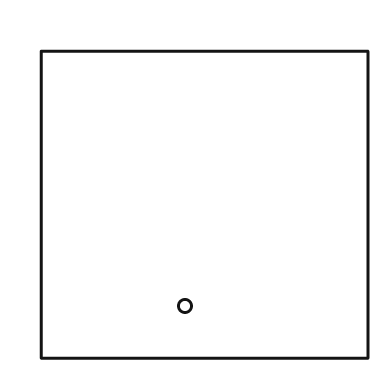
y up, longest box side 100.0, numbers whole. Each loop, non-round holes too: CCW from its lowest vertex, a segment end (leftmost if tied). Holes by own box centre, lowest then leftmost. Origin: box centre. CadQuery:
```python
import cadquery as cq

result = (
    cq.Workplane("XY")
    .moveTo(-50.0, -47.0)
    .lineTo(50.0, -47.0)
    .lineTo(50.0, 47.0)
    .lineTo(-50.0, 47.0)
    .close()
    .moveTo(-6.0, -31.0)
    .circle(2.0)
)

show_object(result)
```